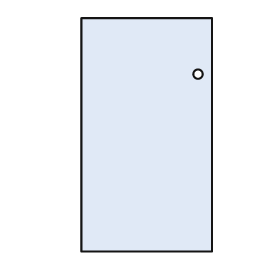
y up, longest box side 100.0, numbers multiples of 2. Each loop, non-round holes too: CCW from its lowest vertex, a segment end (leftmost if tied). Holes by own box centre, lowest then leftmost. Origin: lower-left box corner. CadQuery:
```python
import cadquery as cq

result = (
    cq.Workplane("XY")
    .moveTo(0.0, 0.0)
    .lineTo(56.0, 0.0)
    .lineTo(56.0, 100.0)
    .lineTo(0.0, 100.0)
    .close()
    .moveTo(50.0, 76.0)
    .circle(2.0)
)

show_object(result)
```